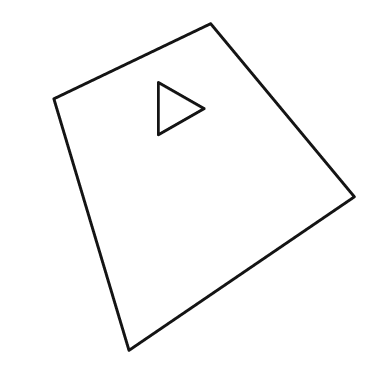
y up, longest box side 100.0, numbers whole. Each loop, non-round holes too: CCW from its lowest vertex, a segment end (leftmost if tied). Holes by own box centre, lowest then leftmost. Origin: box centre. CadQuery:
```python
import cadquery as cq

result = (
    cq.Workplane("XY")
    .moveTo(-23.0, -50.0)
    .lineTo(46.0, -3.0)
    .lineTo(2.0, 50.0)
    .lineTo(-46.0, 27.0)
    .close()
    .moveTo(-14.0, 16.0)
    .lineTo(0.0, 24.0)
    .lineTo(-14.0, 32.0)
    .close()
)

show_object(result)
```